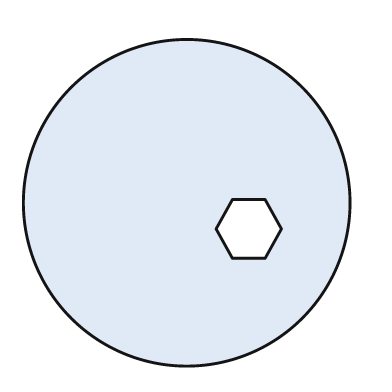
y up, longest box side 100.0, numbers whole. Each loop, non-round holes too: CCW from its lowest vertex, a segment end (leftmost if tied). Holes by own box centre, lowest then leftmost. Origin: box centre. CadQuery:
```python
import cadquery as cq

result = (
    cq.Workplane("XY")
    .moveTo(0.0, 0.0)
    .circle(50.0)
    .moveTo(14.0, -17.0)
    .lineTo(24.0, -17.0)
    .lineTo(29.0, -8.0)
    .lineTo(24.0, 1.0)
    .lineTo(14.0, 1.0)
    .lineTo(9.0, -8.0)
    .close()
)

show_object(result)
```